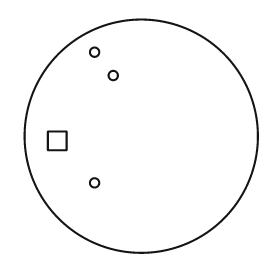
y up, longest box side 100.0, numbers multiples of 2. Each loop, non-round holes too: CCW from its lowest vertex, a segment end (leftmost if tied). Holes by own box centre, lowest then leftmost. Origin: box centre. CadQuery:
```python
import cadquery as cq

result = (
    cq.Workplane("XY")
    .moveTo(0.0, 0.0)
    .circle(50.0)
    .moveTo(-20.0, -20.0)
    .circle(2.0)
    .moveTo(-40.0, -6.0)
    .lineTo(-32.0, -6.0)
    .lineTo(-32.0, 2.0)
    .lineTo(-40.0, 2.0)
    .close()
    .moveTo(-12.0, 26.0)
    .circle(2.0)
    .moveTo(-20.0, 36.0)
    .circle(2.0)
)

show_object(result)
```